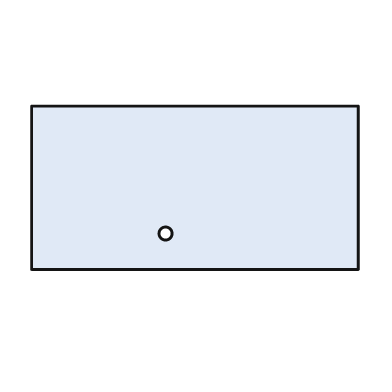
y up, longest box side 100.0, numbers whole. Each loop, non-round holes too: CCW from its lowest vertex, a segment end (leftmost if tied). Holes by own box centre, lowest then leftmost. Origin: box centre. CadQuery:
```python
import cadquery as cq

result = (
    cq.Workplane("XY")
    .moveTo(-50.0, -25.0)
    .lineTo(50.0, -25.0)
    .lineTo(50.0, 25.0)
    .lineTo(-50.0, 25.0)
    .close()
    .moveTo(-9.0, -14.0)
    .circle(2.0)
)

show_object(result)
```